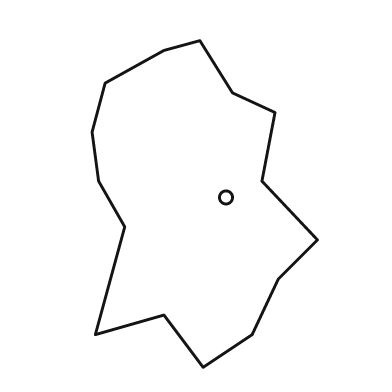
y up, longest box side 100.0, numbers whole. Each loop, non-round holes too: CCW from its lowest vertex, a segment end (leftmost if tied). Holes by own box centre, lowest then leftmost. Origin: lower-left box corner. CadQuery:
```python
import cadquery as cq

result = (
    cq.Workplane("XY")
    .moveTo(34.0, 0.0)
    .lineTo(49.0, 10.0)
    .lineTo(57.0, 27.0)
    .lineTo(69.0, 39.0)
    .lineTo(52.0, 57.0)
    .lineTo(56.0, 78.0)
    .lineTo(43.0, 84.0)
    .lineTo(33.0, 100.0)
    .lineTo(22.0, 97.0)
    .lineTo(4.0, 87.0)
    .lineTo(0.0, 72.0)
    .lineTo(2.0, 57.0)
    .lineTo(10.0, 43.0)
    .lineTo(1.0, 10.0)
    .lineTo(22.0, 16.0)
    .close()
    .moveTo(41.0, 52.0)
    .circle(2.0)
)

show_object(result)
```